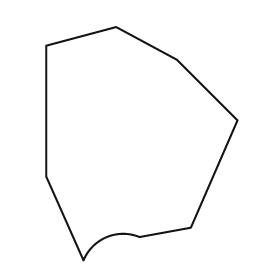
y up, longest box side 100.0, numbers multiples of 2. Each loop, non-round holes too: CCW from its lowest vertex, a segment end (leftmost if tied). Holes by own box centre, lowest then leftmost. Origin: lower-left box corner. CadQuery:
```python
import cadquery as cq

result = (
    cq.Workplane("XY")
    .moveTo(16.0, 0.0)
    .threePointArc((26.0, 10.0), (40.0, 10.0))
    .lineTo(62.0, 14.0)
    .lineTo(82.0, 60.0)
    .lineTo(56.0, 86.0)
    .lineTo(30.0, 100.0)
    .lineTo(0.0, 92.0)
    .lineTo(0.0, 36.0)
    .close()
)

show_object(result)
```